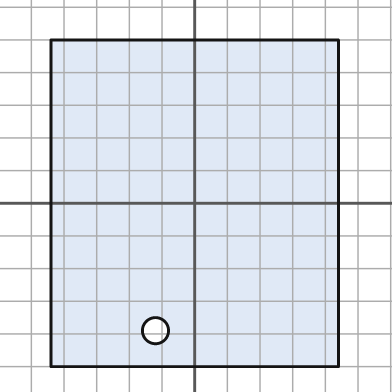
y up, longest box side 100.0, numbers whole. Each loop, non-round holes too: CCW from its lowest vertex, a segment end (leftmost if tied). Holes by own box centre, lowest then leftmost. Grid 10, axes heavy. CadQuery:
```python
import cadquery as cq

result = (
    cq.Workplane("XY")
    .moveTo(-44.0, -50.0)
    .lineTo(44.0, -50.0)
    .lineTo(44.0, 50.0)
    .lineTo(-44.0, 50.0)
    .close()
    .moveTo(-12.0, -39.0)
    .circle(4.0)
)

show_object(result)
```